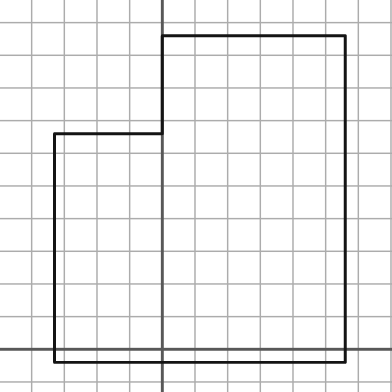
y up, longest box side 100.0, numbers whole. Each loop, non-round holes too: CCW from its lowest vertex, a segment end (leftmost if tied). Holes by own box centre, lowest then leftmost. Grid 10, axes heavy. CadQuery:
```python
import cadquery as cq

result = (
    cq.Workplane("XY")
    .moveTo(-33.0, -4.0)
    .lineTo(56.0, -4.0)
    .lineTo(56.0, 96.0)
    .lineTo(0.0, 96.0)
    .lineTo(0.0, 66.0)
    .lineTo(-33.0, 66.0)
    .close()
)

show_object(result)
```